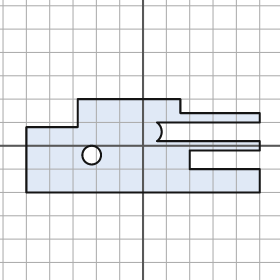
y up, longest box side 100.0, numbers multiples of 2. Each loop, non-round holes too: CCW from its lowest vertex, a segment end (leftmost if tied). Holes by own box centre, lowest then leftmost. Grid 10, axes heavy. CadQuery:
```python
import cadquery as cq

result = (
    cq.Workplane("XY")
    .moveTo(-50.0, -20.0)
    .lineTo(50.0, -20.0)
    .lineTo(50.0, -10.0)
    .lineTo(20.0, -10.0)
    .lineTo(20.0, -2.0)
    .lineTo(50.0, -2.0)
    .lineTo(50.0, 2.0)
    .lineTo(6.0, 2.0)
    .threePointArc((8.0, 6.0), (6.0, 10.0))
    .lineTo(50.0, 10.0)
    .lineTo(50.0, 14.0)
    .lineTo(16.0, 14.0)
    .lineTo(16.0, 20.0)
    .lineTo(-28.0, 20.0)
    .lineTo(-28.0, 8.0)
    .lineTo(-50.0, 8.0)
    .close()
    .moveTo(-22.0, -4.0)
    .circle(4.0)
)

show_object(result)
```